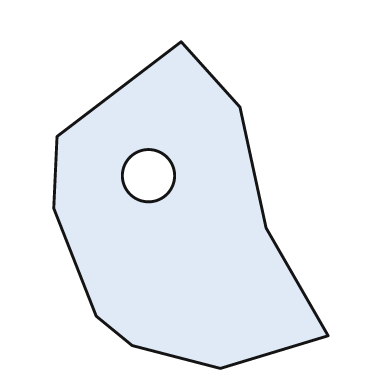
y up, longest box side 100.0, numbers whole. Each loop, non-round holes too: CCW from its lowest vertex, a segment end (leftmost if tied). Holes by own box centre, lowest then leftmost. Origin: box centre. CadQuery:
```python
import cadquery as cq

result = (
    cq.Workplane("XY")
    .moveTo(9.0, -50.0)
    .lineTo(42.0, -40.0)
    .lineTo(23.0, -7.0)
    .lineTo(15.0, 30.0)
    .lineTo(-3.0, 50.0)
    .lineTo(-41.0, 21.0)
    .lineTo(-42.0, -1.0)
    .lineTo(-29.0, -34.0)
    .lineTo(-18.0, -43.0)
    .close()
    .moveTo(-13.0, 9.0)
    .circle(8.0)
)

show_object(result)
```